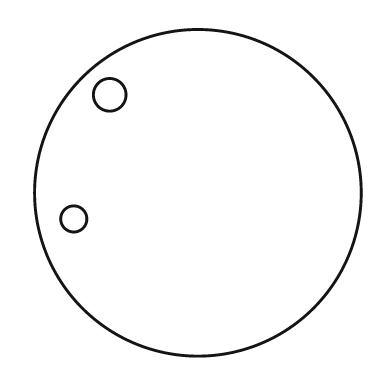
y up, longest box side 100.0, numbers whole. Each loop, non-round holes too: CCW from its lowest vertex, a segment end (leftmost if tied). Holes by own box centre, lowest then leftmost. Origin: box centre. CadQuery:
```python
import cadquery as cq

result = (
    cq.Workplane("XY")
    .moveTo(0.0, 0.0)
    .circle(50.0)
    .moveTo(-38.0, -8.0)
    .circle(4.0)
    .moveTo(-27.0, 30.0)
    .circle(5.0)
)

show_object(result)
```